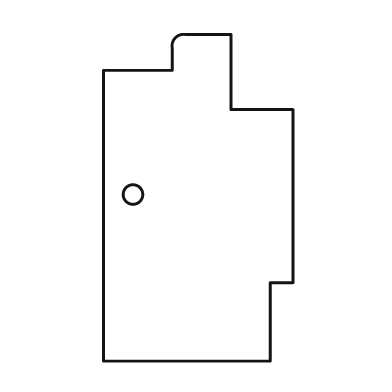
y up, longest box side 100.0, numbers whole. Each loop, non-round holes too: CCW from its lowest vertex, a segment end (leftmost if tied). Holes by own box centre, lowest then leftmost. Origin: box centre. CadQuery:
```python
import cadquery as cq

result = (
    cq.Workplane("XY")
    .moveTo(-29.0, -50.0)
    .lineTo(22.0, -50.0)
    .lineTo(22.0, -26.0)
    .lineTo(29.0, -26.0)
    .lineTo(29.0, 27.0)
    .lineTo(10.0, 27.0)
    .lineTo(10.0, 50.0)
    .lineTo(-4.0, 50.0)
    .threePointArc((-7.0, 49.0), (-8.0, 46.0))
    .lineTo(-8.0, 39.0)
    .lineTo(-29.0, 39.0)
    .close()
    .moveTo(-20.0, 1.0)
    .circle(3.0)
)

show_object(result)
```